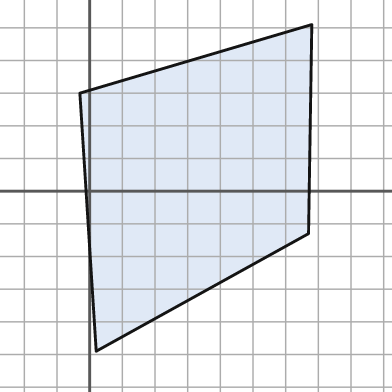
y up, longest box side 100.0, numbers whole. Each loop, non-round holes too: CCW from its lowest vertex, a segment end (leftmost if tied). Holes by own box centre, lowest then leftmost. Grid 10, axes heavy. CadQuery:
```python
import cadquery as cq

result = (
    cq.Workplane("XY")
    .moveTo(2.0, -49.0)
    .lineTo(67.0, -13.0)
    .lineTo(68.0, 51.0)
    .lineTo(-3.0, 30.0)
    .close()
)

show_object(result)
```